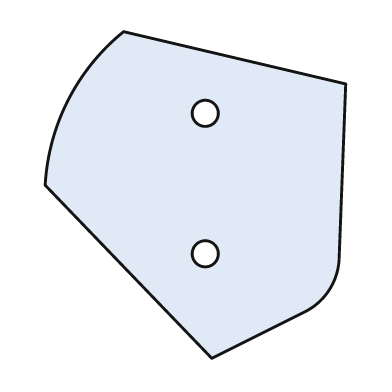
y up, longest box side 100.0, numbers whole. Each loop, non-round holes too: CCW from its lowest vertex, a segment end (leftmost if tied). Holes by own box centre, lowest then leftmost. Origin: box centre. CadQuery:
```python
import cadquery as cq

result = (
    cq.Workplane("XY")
    .moveTo(5.0, -50.0)
    .lineTo(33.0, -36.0)
    .threePointArc((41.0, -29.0), (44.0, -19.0))
    .lineTo(46.0, 34.0)
    .lineTo(-22.0, 50.0)
    .threePointArc((-39.0, 29.0), (-46.0, 3.0))
    .close()
    .moveTo(3.0, -18.0)
    .circle(4.0)
    .moveTo(3.0, 25.0)
    .circle(4.0)
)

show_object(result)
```